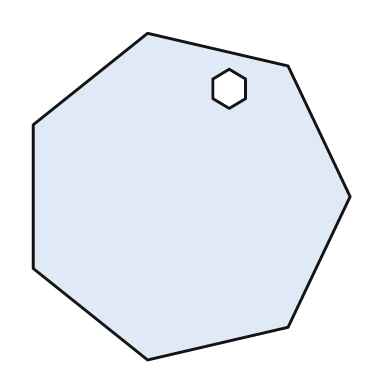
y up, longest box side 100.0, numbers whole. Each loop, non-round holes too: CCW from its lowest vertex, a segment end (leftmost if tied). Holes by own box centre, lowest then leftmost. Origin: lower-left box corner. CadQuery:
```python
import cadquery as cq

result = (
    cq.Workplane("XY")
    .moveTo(35.0, 0.0)
    .lineTo(78.0, 10.0)
    .lineTo(97.0, 50.0)
    .lineTo(78.0, 90.0)
    .lineTo(35.0, 100.0)
    .lineTo(0.0, 72.0)
    .lineTo(0.0, 28.0)
    .close()
    .moveTo(60.0, 77.0)
    .lineTo(65.0, 80.0)
    .lineTo(65.0, 86.0)
    .lineTo(60.0, 89.0)
    .lineTo(55.0, 86.0)
    .lineTo(55.0, 80.0)
    .close()
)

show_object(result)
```